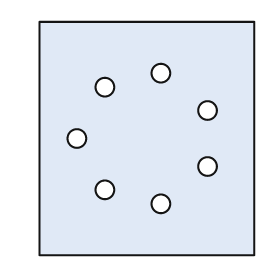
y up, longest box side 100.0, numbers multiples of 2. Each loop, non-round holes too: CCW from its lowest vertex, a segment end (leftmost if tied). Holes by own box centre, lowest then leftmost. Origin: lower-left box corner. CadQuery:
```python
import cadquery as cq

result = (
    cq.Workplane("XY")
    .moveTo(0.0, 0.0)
    .lineTo(92.0, 0.0)
    .lineTo(92.0, 100.0)
    .lineTo(0.0, 100.0)
    .close()
    .moveTo(52.0, 22.0)
    .circle(4.0)
    .moveTo(28.0, 28.0)
    .circle(4.0)
    .moveTo(72.0, 38.0)
    .circle(4.0)
    .moveTo(16.0, 50.0)
    .circle(4.0)
    .moveTo(72.0, 62.0)
    .circle(4.0)
    .moveTo(28.0, 72.0)
    .circle(4.0)
    .moveTo(52.0, 78.0)
    .circle(4.0)
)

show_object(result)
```